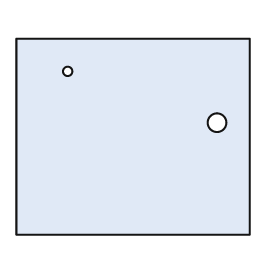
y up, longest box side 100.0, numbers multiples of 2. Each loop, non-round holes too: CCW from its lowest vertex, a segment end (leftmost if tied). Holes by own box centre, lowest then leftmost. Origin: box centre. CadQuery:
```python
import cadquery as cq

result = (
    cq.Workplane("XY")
    .moveTo(-50.0, -42.0)
    .lineTo(50.0, -42.0)
    .lineTo(50.0, 42.0)
    .lineTo(-50.0, 42.0)
    .close()
    .moveTo(36.0, 6.0)
    .circle(4.0)
    .moveTo(-28.0, 28.0)
    .circle(2.0)
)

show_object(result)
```